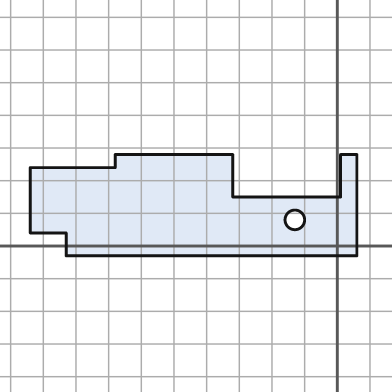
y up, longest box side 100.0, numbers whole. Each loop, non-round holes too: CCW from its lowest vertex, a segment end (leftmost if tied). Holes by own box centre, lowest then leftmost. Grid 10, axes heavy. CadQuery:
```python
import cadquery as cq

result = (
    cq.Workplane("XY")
    .moveTo(-83.0, -3.0)
    .lineTo(6.0, -3.0)
    .lineTo(6.0, 28.0)
    .lineTo(1.0, 28.0)
    .lineTo(1.0, 15.0)
    .lineTo(-32.0, 15.0)
    .lineTo(-32.0, 28.0)
    .lineTo(-68.0, 28.0)
    .lineTo(-68.0, 24.0)
    .lineTo(-94.0, 24.0)
    .lineTo(-94.0, 4.0)
    .lineTo(-83.0, 4.0)
    .close()
    .moveTo(-13.0, 8.0)
    .circle(3.0)
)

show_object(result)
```